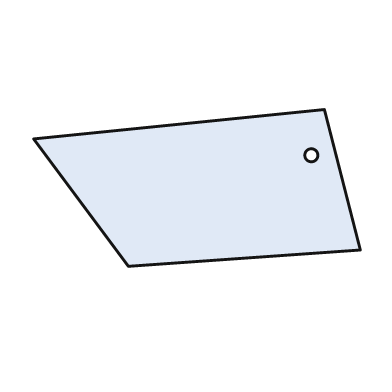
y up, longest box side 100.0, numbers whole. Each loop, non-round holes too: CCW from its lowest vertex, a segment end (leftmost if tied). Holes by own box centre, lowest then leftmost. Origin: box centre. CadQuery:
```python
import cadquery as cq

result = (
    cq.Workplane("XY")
    .moveTo(-21.0, -24.0)
    .lineTo(50.0, -19.0)
    .lineTo(39.0, 24.0)
    .lineTo(-50.0, 15.0)
    .close()
    .moveTo(35.0, 10.0)
    .circle(2.0)
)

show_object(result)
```